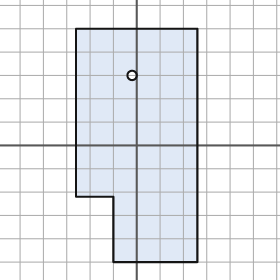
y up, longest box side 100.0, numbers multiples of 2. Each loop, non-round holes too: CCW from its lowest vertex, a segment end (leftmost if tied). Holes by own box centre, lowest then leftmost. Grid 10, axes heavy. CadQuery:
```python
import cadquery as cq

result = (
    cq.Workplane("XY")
    .moveTo(-10.0, -50.0)
    .lineTo(26.0, -50.0)
    .lineTo(26.0, 50.0)
    .lineTo(-26.0, 50.0)
    .lineTo(-26.0, -22.0)
    .lineTo(-10.0, -22.0)
    .close()
    .moveTo(-2.0, 30.0)
    .circle(2.0)
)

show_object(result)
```